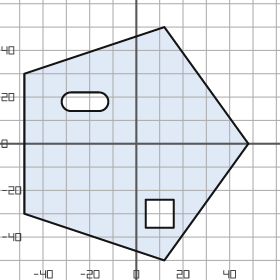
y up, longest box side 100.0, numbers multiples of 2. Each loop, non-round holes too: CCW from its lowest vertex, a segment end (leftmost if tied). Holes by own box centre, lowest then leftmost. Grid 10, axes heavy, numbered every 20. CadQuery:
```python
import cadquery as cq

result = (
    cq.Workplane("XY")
    .moveTo(12.0, -50.0)
    .lineTo(48.0, 0.0)
    .lineTo(12.0, 50.0)
    .lineTo(-48.0, 30.0)
    .lineTo(-48.0, -30.0)
    .close()
    .moveTo(4.0, -36.0)
    .lineTo(16.0, -36.0)
    .lineTo(16.0, -24.0)
    .lineTo(4.0, -24.0)
    .close()
    .moveTo(-28.0, 14.0)
    .lineTo(-16.0, 14.0)
    .threePointArc((-12.0, 18.0), (-16.0, 22.0))
    .lineTo(-28.0, 22.0)
    .threePointArc((-32.0, 18.0), (-28.0, 14.0))
    .close()
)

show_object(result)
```